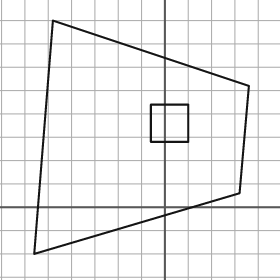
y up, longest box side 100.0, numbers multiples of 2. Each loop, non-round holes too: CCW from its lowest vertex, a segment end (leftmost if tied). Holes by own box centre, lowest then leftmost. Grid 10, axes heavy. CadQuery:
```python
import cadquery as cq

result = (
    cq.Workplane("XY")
    .moveTo(-56.0, -20.0)
    .lineTo(32.0, 6.0)
    .lineTo(36.0, 52.0)
    .lineTo(-48.0, 80.0)
    .close()
    .moveTo(-6.0, 28.0)
    .lineTo(10.0, 28.0)
    .lineTo(10.0, 44.0)
    .lineTo(-6.0, 44.0)
    .close()
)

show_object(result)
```